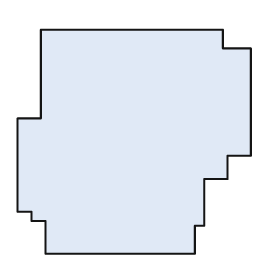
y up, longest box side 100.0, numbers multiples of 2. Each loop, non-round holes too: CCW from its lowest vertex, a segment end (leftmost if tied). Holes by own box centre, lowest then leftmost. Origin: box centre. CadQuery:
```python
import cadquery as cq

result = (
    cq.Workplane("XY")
    .moveTo(-38.0, -48.0)
    .lineTo(26.0, -48.0)
    .lineTo(26.0, -36.0)
    .lineTo(30.0, -36.0)
    .lineTo(30.0, -16.0)
    .lineTo(40.0, -16.0)
    .lineTo(40.0, -6.0)
    .lineTo(50.0, -6.0)
    .lineTo(50.0, 40.0)
    .lineTo(38.0, 40.0)
    .lineTo(38.0, 48.0)
    .lineTo(-40.0, 48.0)
    .lineTo(-40.0, 10.0)
    .lineTo(-50.0, 10.0)
    .lineTo(-50.0, -30.0)
    .lineTo(-44.0, -30.0)
    .lineTo(-44.0, -34.0)
    .lineTo(-38.0, -34.0)
    .close()
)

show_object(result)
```